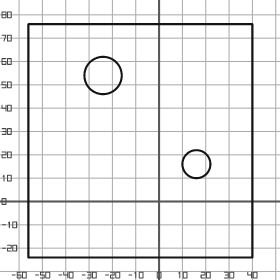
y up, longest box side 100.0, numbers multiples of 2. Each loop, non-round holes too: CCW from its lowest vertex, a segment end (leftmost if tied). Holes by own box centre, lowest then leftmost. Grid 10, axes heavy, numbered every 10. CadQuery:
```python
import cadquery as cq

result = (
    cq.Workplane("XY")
    .moveTo(-56.0, -24.0)
    .lineTo(40.0, -24.0)
    .lineTo(40.0, 76.0)
    .lineTo(-56.0, 76.0)
    .close()
    .moveTo(16.0, 16.0)
    .circle(6.0)
    .moveTo(-24.0, 54.0)
    .circle(8.0)
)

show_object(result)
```